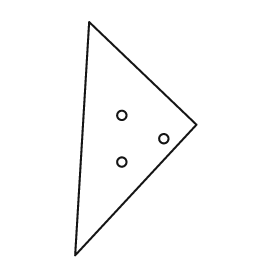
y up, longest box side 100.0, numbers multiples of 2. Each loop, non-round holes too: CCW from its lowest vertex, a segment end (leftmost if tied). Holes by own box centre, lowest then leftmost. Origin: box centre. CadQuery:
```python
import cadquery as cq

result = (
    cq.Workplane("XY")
    .moveTo(-26.0, -50.0)
    .lineTo(26.0, 6.0)
    .lineTo(-20.0, 50.0)
    .close()
    .moveTo(-6.0, -10.0)
    .circle(2.0)
    .moveTo(12.0, 0.0)
    .circle(2.0)
    .moveTo(-6.0, 10.0)
    .circle(2.0)
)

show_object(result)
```